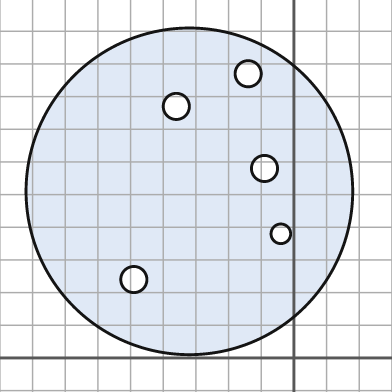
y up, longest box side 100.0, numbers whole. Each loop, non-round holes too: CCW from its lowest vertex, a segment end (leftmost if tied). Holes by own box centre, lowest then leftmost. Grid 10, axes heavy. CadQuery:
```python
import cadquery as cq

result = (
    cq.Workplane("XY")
    .moveTo(-32.0, 51.0)
    .circle(50.0)
    .moveTo(-49.0, 24.0)
    .circle(4.0)
    .moveTo(-4.0, 38.0)
    .circle(3.0)
    .moveTo(-9.0, 58.0)
    .circle(4.0)
    .moveTo(-36.0, 77.0)
    .circle(4.0)
    .moveTo(-14.0, 87.0)
    .circle(4.0)
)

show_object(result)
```